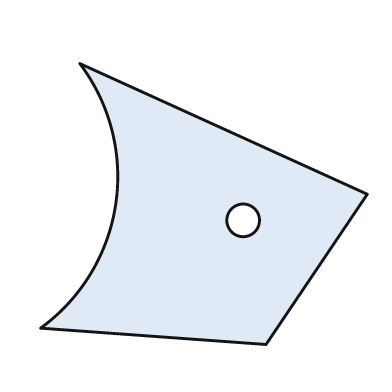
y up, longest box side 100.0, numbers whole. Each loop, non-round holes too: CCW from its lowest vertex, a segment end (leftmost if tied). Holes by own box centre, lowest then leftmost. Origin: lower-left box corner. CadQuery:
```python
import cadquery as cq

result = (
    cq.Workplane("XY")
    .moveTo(69.0, 0.0)
    .lineTo(100.0, 46.0)
    .lineTo(12.0, 86.0)
    .threePointArc((23.0, 43.0), (0.0, 5.0))
    .close()
    .moveTo(62.0, 38.0)
    .circle(5.0)
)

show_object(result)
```